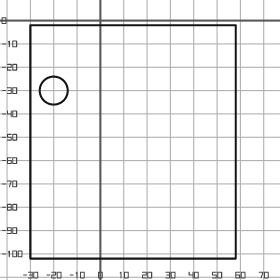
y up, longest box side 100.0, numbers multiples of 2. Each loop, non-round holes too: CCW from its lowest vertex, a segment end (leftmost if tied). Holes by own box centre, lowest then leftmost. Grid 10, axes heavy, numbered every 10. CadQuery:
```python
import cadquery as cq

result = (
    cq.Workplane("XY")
    .moveTo(-30.0, -102.0)
    .lineTo(58.0, -102.0)
    .lineTo(58.0, -2.0)
    .lineTo(-30.0, -2.0)
    .close()
    .moveTo(-20.0, -30.0)
    .circle(6.0)
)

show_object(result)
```